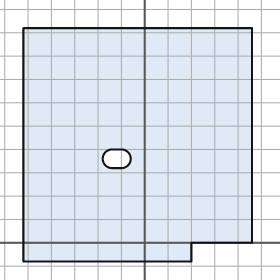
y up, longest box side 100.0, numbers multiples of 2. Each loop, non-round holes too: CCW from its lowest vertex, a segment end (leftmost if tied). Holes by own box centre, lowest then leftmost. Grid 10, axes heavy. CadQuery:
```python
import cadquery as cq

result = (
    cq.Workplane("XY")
    .moveTo(-52.0, -8.0)
    .lineTo(20.0, -8.0)
    .lineTo(20.0, 0.0)
    .lineTo(46.0, 0.0)
    .lineTo(46.0, 92.0)
    .lineTo(-52.0, 92.0)
    .close()
    .moveTo(-14.0, 32.0)
    .lineTo(-10.0, 32.0)
    .threePointArc((-6.0, 36.0), (-10.0, 40.0))
    .lineTo(-14.0, 40.0)
    .threePointArc((-18.0, 36.0), (-14.0, 32.0))
    .close()
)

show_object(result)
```